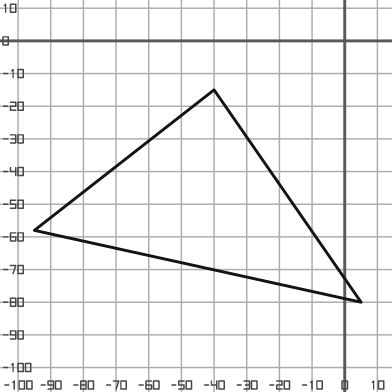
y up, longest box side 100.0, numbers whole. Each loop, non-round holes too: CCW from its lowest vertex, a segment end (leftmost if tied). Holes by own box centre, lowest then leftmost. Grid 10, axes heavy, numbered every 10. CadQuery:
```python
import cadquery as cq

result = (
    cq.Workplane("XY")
    .moveTo(5.0, -80.0)
    .lineTo(-40.0, -15.0)
    .lineTo(-95.0, -58.0)
    .close()
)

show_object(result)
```